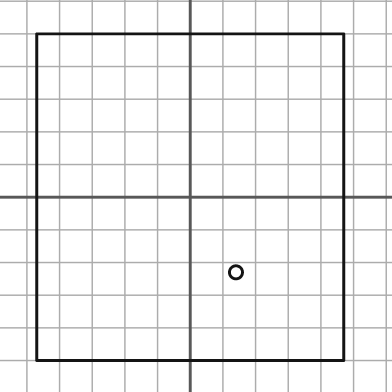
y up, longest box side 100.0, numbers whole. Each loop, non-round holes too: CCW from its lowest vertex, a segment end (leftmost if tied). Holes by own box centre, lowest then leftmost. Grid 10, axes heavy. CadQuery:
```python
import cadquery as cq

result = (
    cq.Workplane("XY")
    .moveTo(-47.0, -50.0)
    .lineTo(47.0, -50.0)
    .lineTo(47.0, 50.0)
    .lineTo(-47.0, 50.0)
    .close()
    .moveTo(14.0, -23.0)
    .circle(2.0)
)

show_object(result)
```